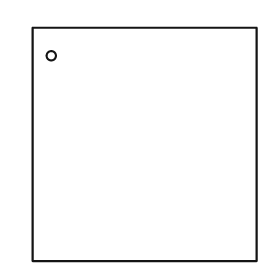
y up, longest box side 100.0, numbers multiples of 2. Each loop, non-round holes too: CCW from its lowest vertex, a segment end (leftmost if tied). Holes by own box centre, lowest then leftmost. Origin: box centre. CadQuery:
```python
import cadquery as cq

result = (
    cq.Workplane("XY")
    .moveTo(-48.0, -50.0)
    .lineTo(48.0, -50.0)
    .lineTo(48.0, 50.0)
    .lineTo(-48.0, 50.0)
    .close()
    .moveTo(-40.0, 38.0)
    .circle(2.0)
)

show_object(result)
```